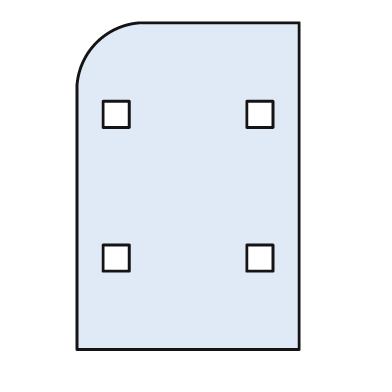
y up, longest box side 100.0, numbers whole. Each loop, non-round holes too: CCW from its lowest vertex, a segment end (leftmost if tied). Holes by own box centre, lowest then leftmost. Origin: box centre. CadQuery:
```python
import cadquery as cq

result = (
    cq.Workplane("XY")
    .moveTo(-34.0, -50.0)
    .lineTo(34.0, -50.0)
    .lineTo(34.0, 50.0)
    .lineTo(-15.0, 50.0)
    .threePointArc((-28.0, 44.0), (-34.0, 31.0))
    .close()
    .moveTo(-26.0, -26.0)
    .lineTo(-18.0, -26.0)
    .lineTo(-18.0, -18.0)
    .lineTo(-26.0, -18.0)
    .close()
    .moveTo(18.0, -26.0)
    .lineTo(26.0, -26.0)
    .lineTo(26.0, -18.0)
    .lineTo(18.0, -18.0)
    .close()
    .moveTo(-26.0, 18.0)
    .lineTo(-18.0, 18.0)
    .lineTo(-18.0, 26.0)
    .lineTo(-26.0, 26.0)
    .close()
    .moveTo(18.0, 18.0)
    .lineTo(26.0, 18.0)
    .lineTo(26.0, 26.0)
    .lineTo(18.0, 26.0)
    .close()
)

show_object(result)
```